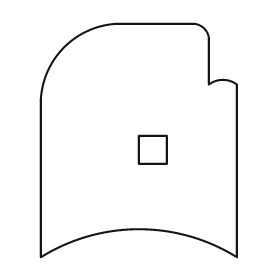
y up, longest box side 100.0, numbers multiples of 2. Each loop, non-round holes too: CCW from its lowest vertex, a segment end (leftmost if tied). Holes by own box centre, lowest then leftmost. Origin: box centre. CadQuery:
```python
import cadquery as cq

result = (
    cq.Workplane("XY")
    .moveTo(-42.0, -50.0)
    .threePointArc((0.0, -38.0), (42.0, -50.0))
    .lineTo(42.0, 24.0)
    .threePointArc((36.0, 26.0), (30.0, 24.0))
    .lineTo(30.0, 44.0)
    .threePointArc((28.0, 48.0), (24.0, 50.0))
    .lineTo(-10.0, 50.0)
    .threePointArc((-32.0, 40.0), (-42.0, 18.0))
    .close()
    .moveTo(0.0, -10.0)
    .lineTo(12.0, -10.0)
    .lineTo(12.0, 2.0)
    .lineTo(0.0, 2.0)
    .close()
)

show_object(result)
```